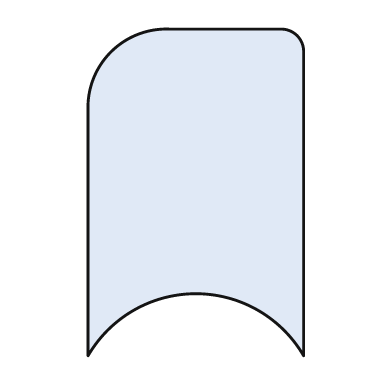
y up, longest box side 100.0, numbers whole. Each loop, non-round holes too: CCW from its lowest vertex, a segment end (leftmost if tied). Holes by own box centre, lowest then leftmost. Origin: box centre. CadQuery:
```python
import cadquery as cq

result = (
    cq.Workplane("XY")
    .moveTo(-33.0, -50.0)
    .threePointArc((0.0, -31.0), (33.0, -50.0))
    .lineTo(33.0, 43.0)
    .threePointArc((31.0, 48.0), (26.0, 50.0))
    .lineTo(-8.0, 50.0)
    .threePointArc((-26.0, 43.0), (-33.0, 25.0))
    .close()
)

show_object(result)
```